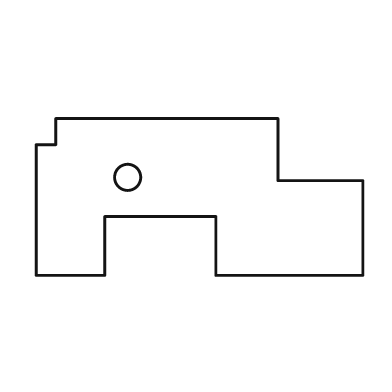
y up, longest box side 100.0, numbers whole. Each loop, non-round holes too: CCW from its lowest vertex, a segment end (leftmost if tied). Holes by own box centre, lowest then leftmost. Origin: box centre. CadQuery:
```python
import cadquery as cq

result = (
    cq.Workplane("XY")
    .moveTo(-50.0, -24.0)
    .lineTo(-29.0, -24.0)
    .lineTo(-29.0, -6.0)
    .lineTo(5.0, -6.0)
    .lineTo(5.0, -24.0)
    .lineTo(50.0, -24.0)
    .lineTo(50.0, 5.0)
    .lineTo(24.0, 5.0)
    .lineTo(24.0, 24.0)
    .lineTo(-44.0, 24.0)
    .lineTo(-44.0, 16.0)
    .lineTo(-50.0, 16.0)
    .close()
    .moveTo(-22.0, 6.0)
    .circle(4.0)
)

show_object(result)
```